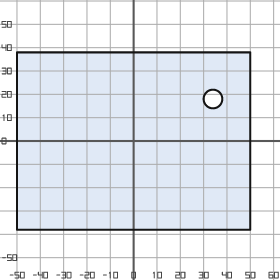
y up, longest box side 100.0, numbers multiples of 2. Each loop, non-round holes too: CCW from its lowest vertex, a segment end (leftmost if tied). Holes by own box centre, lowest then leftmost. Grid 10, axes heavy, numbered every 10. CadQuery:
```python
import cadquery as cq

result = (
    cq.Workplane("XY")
    .moveTo(-50.0, -38.0)
    .lineTo(50.0, -38.0)
    .lineTo(50.0, 38.0)
    .lineTo(-50.0, 38.0)
    .close()
    .moveTo(34.0, 18.0)
    .circle(4.0)
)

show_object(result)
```